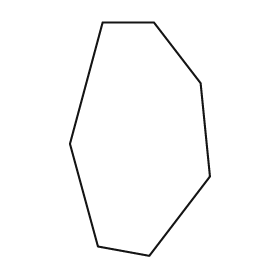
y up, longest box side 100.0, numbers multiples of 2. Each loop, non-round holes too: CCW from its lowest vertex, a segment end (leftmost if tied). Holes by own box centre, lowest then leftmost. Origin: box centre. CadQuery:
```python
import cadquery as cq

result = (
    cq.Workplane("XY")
    .moveTo(4.0, -50.0)
    .lineTo(30.0, -16.0)
    .lineTo(26.0, 24.0)
    .lineTo(6.0, 50.0)
    .lineTo(-16.0, 50.0)
    .lineTo(-30.0, -2.0)
    .lineTo(-18.0, -46.0)
    .close()
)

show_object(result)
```